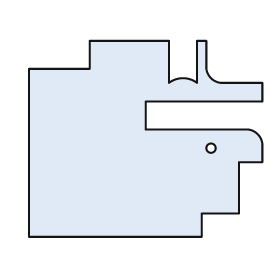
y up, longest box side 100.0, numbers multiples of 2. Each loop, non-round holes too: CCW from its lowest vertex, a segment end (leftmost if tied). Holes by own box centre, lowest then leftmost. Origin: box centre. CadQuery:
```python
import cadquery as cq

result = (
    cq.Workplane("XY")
    .moveTo(-50.0, -42.0)
    .lineTo(24.0, -42.0)
    .lineTo(24.0, -32.0)
    .lineTo(40.0, -32.0)
    .lineTo(40.0, -10.0)
    .lineTo(50.0, -10.0)
    .lineTo(50.0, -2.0)
    .threePointArc((48.0, 2.0), (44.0, 4.0))
    .lineTo(0.0, 4.0)
    .lineTo(0.0, 16.0)
    .lineTo(50.0, 16.0)
    .lineTo(50.0, 24.0)
    .lineTo(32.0, 24.0)
    .threePointArc((28.0, 26.0), (26.0, 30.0))
    .lineTo(26.0, 42.0)
    .lineTo(22.0, 42.0)
    .lineTo(22.0, 24.0)
    .threePointArc((16.0, 26.0), (10.0, 24.0))
    .lineTo(10.0, 42.0)
    .lineTo(-24.0, 42.0)
    .lineTo(-24.0, 30.0)
    .lineTo(-50.0, 30.0)
    .close()
    .moveTo(28.0, -4.0)
    .circle(2.0)
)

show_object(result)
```